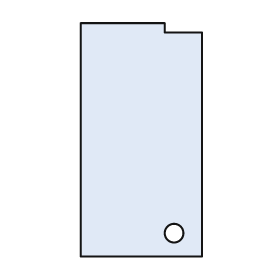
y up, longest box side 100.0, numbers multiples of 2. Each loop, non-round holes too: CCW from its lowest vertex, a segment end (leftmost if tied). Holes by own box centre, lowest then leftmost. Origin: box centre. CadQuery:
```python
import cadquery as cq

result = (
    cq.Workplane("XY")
    .moveTo(-26.0, -50.0)
    .lineTo(26.0, -50.0)
    .lineTo(26.0, 46.0)
    .lineTo(10.0, 46.0)
    .lineTo(10.0, 50.0)
    .lineTo(-26.0, 50.0)
    .close()
    .moveTo(14.0, -40.0)
    .circle(4.0)
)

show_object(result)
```